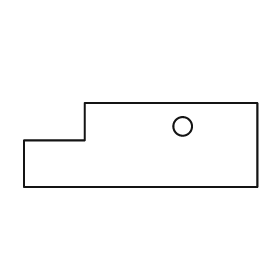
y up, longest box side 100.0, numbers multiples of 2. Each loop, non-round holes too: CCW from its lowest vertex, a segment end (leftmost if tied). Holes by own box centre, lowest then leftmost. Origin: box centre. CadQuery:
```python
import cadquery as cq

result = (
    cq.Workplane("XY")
    .moveTo(-50.0, -18.0)
    .lineTo(50.0, -18.0)
    .lineTo(50.0, 18.0)
    .lineTo(-24.0, 18.0)
    .lineTo(-24.0, 2.0)
    .lineTo(-50.0, 2.0)
    .close()
    .moveTo(18.0, 8.0)
    .circle(4.0)
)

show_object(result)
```